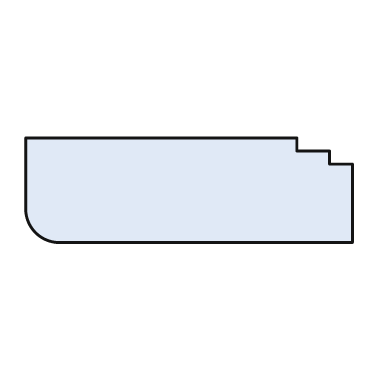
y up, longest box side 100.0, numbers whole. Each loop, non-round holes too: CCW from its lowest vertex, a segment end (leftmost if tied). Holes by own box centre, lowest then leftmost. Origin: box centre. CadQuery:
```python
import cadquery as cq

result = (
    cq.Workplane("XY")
    .moveTo(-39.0, -16.0)
    .lineTo(50.0, -16.0)
    .lineTo(50.0, 8.0)
    .lineTo(43.0, 8.0)
    .lineTo(43.0, 12.0)
    .lineTo(33.0, 12.0)
    .lineTo(33.0, 16.0)
    .lineTo(-50.0, 16.0)
    .lineTo(-50.0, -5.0)
    .threePointArc((-47.0, -13.0), (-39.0, -16.0))
    .close()
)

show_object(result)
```